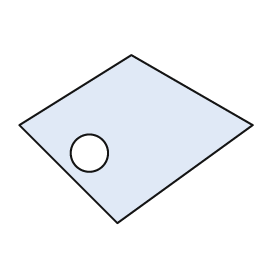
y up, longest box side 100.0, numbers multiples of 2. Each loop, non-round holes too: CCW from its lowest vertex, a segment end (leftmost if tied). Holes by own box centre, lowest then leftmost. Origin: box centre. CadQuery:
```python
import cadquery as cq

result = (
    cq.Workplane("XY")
    .moveTo(-8.0, -36.0)
    .lineTo(50.0, 6.0)
    .lineTo(-2.0, 36.0)
    .lineTo(-50.0, 6.0)
    .close()
    .moveTo(-20.0, -6.0)
    .circle(8.0)
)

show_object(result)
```